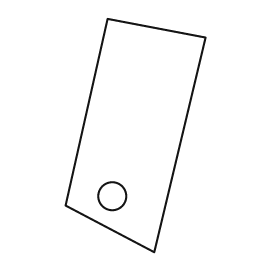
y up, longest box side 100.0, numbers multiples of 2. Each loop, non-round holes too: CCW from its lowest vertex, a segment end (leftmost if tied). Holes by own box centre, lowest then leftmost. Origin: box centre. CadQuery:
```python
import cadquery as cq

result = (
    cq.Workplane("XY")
    .moveTo(8.0, -50.0)
    .lineTo(30.0, 42.0)
    .lineTo(-12.0, 50.0)
    .lineTo(-30.0, -30.0)
    .close()
    .moveTo(-10.0, -26.0)
    .circle(6.0)
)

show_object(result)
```